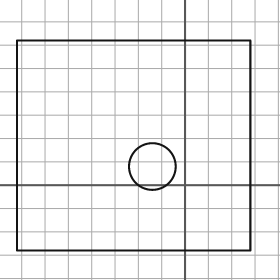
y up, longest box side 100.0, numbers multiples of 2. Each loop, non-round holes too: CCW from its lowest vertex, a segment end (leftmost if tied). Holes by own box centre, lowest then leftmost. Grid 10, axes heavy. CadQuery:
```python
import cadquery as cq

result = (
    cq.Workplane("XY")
    .moveTo(-72.0, -28.0)
    .lineTo(28.0, -28.0)
    .lineTo(28.0, 62.0)
    .lineTo(-72.0, 62.0)
    .close()
    .moveTo(-14.0, 8.0)
    .circle(10.0)
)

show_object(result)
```